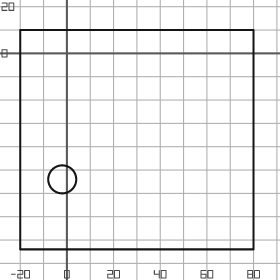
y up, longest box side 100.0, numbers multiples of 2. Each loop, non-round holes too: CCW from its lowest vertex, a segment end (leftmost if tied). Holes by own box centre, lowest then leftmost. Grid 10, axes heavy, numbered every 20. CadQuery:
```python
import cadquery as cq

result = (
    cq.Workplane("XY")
    .moveTo(-20.0, -84.0)
    .lineTo(80.0, -84.0)
    .lineTo(80.0, 10.0)
    .lineTo(-20.0, 10.0)
    .close()
    .moveTo(-2.0, -54.0)
    .circle(6.0)
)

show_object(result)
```